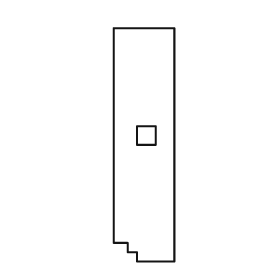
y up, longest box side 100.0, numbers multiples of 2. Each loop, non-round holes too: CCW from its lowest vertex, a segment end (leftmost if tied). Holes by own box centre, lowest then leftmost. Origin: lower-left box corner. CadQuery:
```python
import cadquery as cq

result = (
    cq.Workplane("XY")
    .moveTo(10.0, 0.0)
    .lineTo(26.0, 0.0)
    .lineTo(26.0, 100.0)
    .lineTo(0.0, 100.0)
    .lineTo(0.0, 8.0)
    .lineTo(6.0, 8.0)
    .lineTo(6.0, 4.0)
    .lineTo(10.0, 4.0)
    .close()
    .moveTo(10.0, 50.0)
    .lineTo(18.0, 50.0)
    .lineTo(18.0, 58.0)
    .lineTo(10.0, 58.0)
    .close()
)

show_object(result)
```